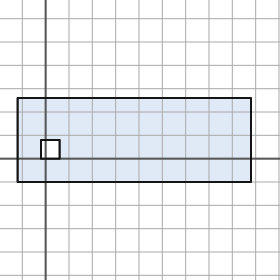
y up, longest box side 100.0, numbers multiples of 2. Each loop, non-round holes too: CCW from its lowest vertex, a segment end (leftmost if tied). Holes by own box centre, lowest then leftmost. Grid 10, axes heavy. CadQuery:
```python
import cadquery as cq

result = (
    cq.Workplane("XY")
    .moveTo(-12.0, -10.0)
    .lineTo(88.0, -10.0)
    .lineTo(88.0, 26.0)
    .lineTo(-12.0, 26.0)
    .close()
    .moveTo(-2.0, 0.0)
    .lineTo(6.0, 0.0)
    .lineTo(6.0, 8.0)
    .lineTo(-2.0, 8.0)
    .close()
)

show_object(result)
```